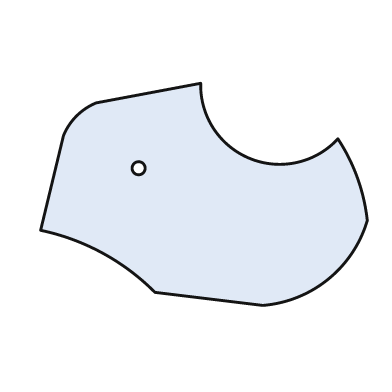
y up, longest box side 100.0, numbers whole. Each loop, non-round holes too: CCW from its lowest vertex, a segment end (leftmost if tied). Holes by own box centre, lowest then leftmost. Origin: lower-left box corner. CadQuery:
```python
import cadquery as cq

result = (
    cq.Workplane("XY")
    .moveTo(68.0, 0.0)
    .threePointArc((88.0, 8.0), (100.0, 26.0))
    .threePointArc((97.0, 39.0), (91.0, 51.0))
    .threePointArc((64.0, 45.0), (49.0, 68.0))
    .lineTo(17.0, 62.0)
    .threePointArc((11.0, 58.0), (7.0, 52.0))
    .lineTo(0.0, 23.0)
    .threePointArc((19.0, 16.0), (35.0, 4.0))
    .close()
    .moveTo(30.0, 42.0)
    .circle(2.0)
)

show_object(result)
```